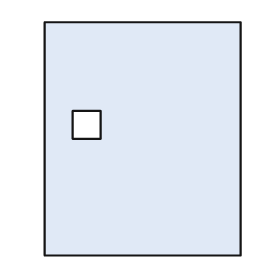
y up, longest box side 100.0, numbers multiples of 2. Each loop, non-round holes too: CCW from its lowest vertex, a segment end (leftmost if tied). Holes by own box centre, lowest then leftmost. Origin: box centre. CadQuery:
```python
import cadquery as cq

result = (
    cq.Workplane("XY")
    .moveTo(-42.0, -50.0)
    .lineTo(42.0, -50.0)
    .lineTo(42.0, 50.0)
    .lineTo(-42.0, 50.0)
    .close()
    .moveTo(-30.0, 0.0)
    .lineTo(-18.0, 0.0)
    .lineTo(-18.0, 12.0)
    .lineTo(-30.0, 12.0)
    .close()
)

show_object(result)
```